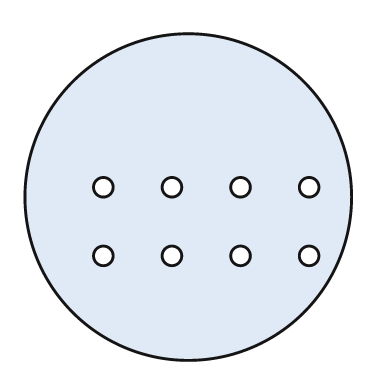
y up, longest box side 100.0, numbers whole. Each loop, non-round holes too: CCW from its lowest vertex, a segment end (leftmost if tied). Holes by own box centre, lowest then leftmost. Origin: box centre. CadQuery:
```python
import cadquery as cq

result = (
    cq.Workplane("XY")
    .moveTo(0.0, 0.0)
    .circle(50.0)
    .moveTo(-26.0, -18.0)
    .circle(3.0)
    .moveTo(-5.0, -18.0)
    .circle(3.0)
    .moveTo(16.0, -18.0)
    .circle(3.0)
    .moveTo(37.0, -18.0)
    .circle(3.0)
    .moveTo(-26.0, 3.0)
    .circle(3.0)
    .moveTo(-5.0, 3.0)
    .circle(3.0)
    .moveTo(16.0, 3.0)
    .circle(3.0)
    .moveTo(37.0, 3.0)
    .circle(3.0)
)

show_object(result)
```